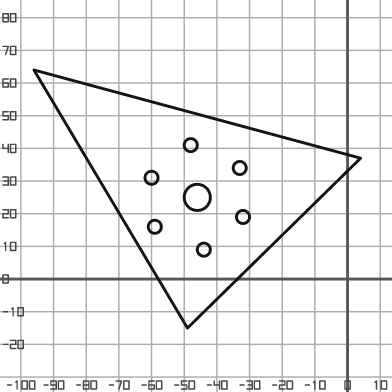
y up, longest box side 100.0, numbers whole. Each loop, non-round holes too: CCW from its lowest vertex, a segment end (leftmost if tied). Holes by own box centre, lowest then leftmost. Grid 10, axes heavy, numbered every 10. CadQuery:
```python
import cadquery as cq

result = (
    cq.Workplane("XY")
    .moveTo(-49.0, -15.0)
    .lineTo(4.0, 37.0)
    .lineTo(-96.0, 64.0)
    .close()
    .moveTo(-44.0, 9.0)
    .circle(2.0)
    .moveTo(-59.0, 16.0)
    .circle(2.0)
    .moveTo(-32.0, 19.0)
    .circle(2.0)
    .moveTo(-46.0, 25.0)
    .circle(4.0)
    .moveTo(-60.0, 31.0)
    .circle(2.0)
    .moveTo(-33.0, 34.0)
    .circle(2.0)
    .moveTo(-48.0, 41.0)
    .circle(2.0)
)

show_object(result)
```